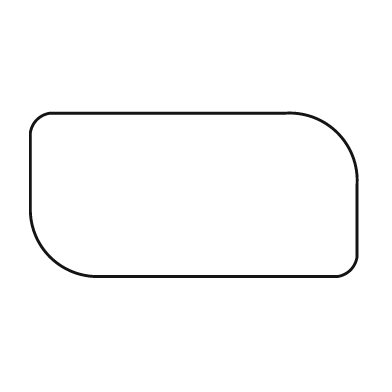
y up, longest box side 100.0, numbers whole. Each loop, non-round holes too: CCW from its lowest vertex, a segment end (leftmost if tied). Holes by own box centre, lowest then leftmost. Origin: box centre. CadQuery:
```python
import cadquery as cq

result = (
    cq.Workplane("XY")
    .moveTo(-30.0, -25.0)
    .lineTo(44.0, -25.0)
    .threePointArc((48.0, -23.0), (50.0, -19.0))
    .lineTo(50.0, 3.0)
    .threePointArc((44.0, 19.0), (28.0, 25.0))
    .lineTo(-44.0, 25.0)
    .threePointArc((-48.0, 23.0), (-50.0, 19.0))
    .lineTo(-50.0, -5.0)
    .threePointArc((-44.0, -19.0), (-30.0, -25.0))
    .close()
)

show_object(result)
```